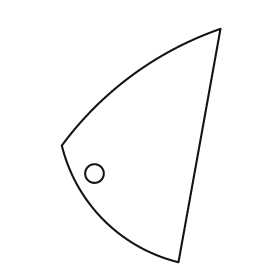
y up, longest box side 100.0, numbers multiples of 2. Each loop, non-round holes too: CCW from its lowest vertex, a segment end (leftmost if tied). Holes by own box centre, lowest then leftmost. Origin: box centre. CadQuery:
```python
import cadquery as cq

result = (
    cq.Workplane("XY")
    .moveTo(16.0, -50.0)
    .lineTo(34.0, 50.0)
    .threePointArc((-4.0, 30.0), (-34.0, 0.0))
    .threePointArc((-16.0, -32.0), (16.0, -50.0))
    .close()
    .moveTo(-20.0, -12.0)
    .circle(4.0)
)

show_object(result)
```